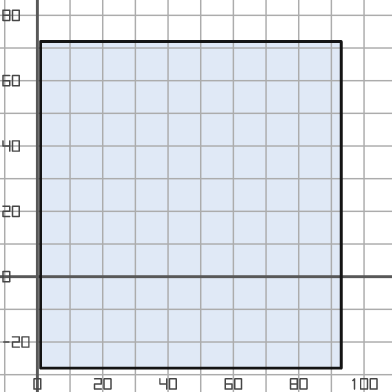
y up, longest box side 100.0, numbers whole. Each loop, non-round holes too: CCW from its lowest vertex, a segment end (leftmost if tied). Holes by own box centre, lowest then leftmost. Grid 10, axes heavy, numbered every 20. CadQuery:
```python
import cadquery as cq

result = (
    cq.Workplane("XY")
    .moveTo(1.0, -28.0)
    .lineTo(93.0, -28.0)
    .lineTo(93.0, 72.0)
    .lineTo(1.0, 72.0)
    .close()
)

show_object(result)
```